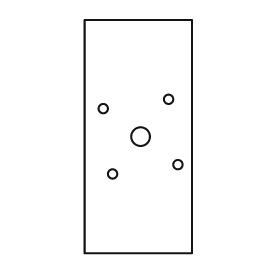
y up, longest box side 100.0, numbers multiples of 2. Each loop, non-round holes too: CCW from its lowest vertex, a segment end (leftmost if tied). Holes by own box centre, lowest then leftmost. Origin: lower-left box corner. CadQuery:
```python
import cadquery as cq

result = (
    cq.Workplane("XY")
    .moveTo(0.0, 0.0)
    .lineTo(46.0, 0.0)
    .lineTo(46.0, 100.0)
    .lineTo(0.0, 100.0)
    .close()
    .moveTo(12.0, 34.0)
    .circle(2.0)
    .moveTo(40.0, 38.0)
    .circle(2.0)
    .moveTo(24.0, 50.0)
    .circle(4.0)
    .moveTo(8.0, 62.0)
    .circle(2.0)
    .moveTo(36.0, 66.0)
    .circle(2.0)
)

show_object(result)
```